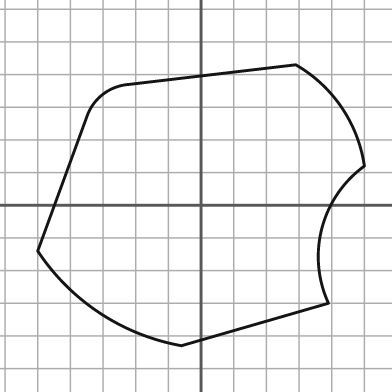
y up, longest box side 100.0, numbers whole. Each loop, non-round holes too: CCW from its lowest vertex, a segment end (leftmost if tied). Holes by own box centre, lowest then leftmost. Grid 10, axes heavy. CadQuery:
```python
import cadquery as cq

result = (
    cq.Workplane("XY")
    .moveTo(-6.0, -43.0)
    .lineTo(39.0, -30.0)
    .threePointArc((37.0, -7.0), (50.0, 12.0))
    .threePointArc((43.0, 30.0), (29.0, 43.0))
    .lineTo(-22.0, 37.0)
    .threePointArc((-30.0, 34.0), (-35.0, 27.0))
    .lineTo(-50.0, -14.0)
    .threePointArc((-31.0, -33.0), (-6.0, -43.0))
    .close()
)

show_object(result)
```